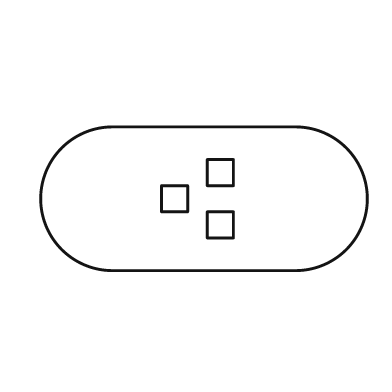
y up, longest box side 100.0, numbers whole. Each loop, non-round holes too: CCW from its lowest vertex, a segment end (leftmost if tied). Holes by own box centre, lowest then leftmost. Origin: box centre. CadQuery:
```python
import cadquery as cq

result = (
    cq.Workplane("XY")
    .moveTo(-28.0, -22.0)
    .lineTo(28.0, -22.0)
    .threePointArc((50.0, 0.0), (28.0, 22.0))
    .lineTo(-28.0, 22.0)
    .threePointArc((-50.0, 0.0), (-28.0, -22.0))
    .close()
    .moveTo(1.0, -12.0)
    .lineTo(9.0, -12.0)
    .lineTo(9.0, -4.0)
    .lineTo(1.0, -4.0)
    .close()
    .moveTo(-13.0, -4.0)
    .lineTo(-5.0, -4.0)
    .lineTo(-5.0, 4.0)
    .lineTo(-13.0, 4.0)
    .close()
    .moveTo(1.0, 4.0)
    .lineTo(9.0, 4.0)
    .lineTo(9.0, 12.0)
    .lineTo(1.0, 12.0)
    .close()
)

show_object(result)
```